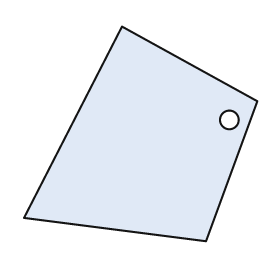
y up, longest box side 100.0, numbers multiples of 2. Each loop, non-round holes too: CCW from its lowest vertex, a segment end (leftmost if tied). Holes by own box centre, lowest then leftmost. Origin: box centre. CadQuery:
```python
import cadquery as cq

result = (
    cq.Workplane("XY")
    .moveTo(28.0, -46.0)
    .lineTo(50.0, 14.0)
    .lineTo(-8.0, 46.0)
    .lineTo(-50.0, -36.0)
    .close()
    .moveTo(38.0, 6.0)
    .circle(4.0)
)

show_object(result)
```